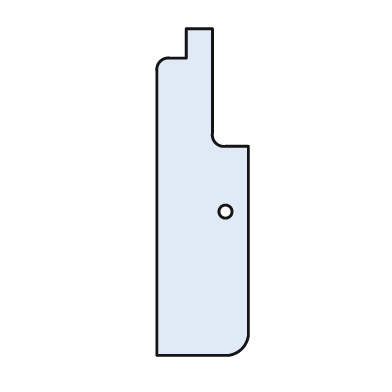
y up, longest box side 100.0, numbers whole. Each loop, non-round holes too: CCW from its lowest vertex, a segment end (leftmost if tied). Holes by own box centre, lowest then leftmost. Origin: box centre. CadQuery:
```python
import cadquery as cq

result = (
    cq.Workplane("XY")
    .moveTo(-14.0, -50.0)
    .lineTo(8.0, -50.0)
    .threePointArc((12.0, -48.0), (14.0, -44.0))
    .lineTo(14.0, 14.0)
    .lineTo(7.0, 14.0)
    .threePointArc((4.0, 15.0), (3.0, 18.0))
    .lineTo(3.0, 50.0)
    .lineTo(-5.0, 50.0)
    .lineTo(-5.0, 41.0)
    .lineTo(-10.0, 41.0)
    .threePointArc((-13.0, 40.0), (-14.0, 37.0))
    .close()
    .moveTo(7.0, -6.0)
    .circle(2.0)
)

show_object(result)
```